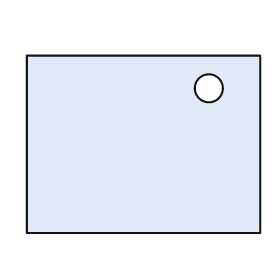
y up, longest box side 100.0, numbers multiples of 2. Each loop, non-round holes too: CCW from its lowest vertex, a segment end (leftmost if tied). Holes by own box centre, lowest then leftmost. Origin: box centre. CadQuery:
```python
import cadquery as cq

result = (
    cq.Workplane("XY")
    .moveTo(-50.0, -38.0)
    .lineTo(50.0, -38.0)
    .lineTo(50.0, 38.0)
    .lineTo(-50.0, 38.0)
    .close()
    .moveTo(28.0, 24.0)
    .circle(6.0)
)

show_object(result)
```